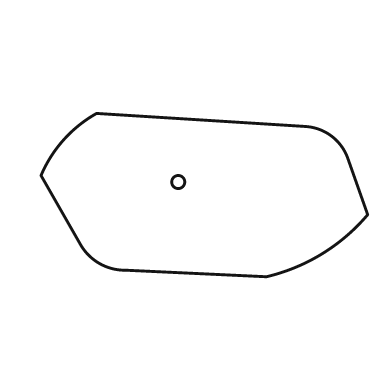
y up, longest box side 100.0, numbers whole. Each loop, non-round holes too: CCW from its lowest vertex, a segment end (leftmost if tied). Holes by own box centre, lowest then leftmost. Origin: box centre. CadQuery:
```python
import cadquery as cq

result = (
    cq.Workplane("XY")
    .moveTo(19.0, -25.0)
    .threePointArc((36.0, -18.0), (50.0, -6.0))
    .lineTo(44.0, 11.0)
    .threePointArc((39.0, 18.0), (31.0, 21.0))
    .lineTo(-33.0, 25.0)
    .threePointArc((-43.0, 17.0), (-50.0, 6.0))
    .lineTo(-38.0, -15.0)
    .threePointArc((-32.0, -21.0), (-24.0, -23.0))
    .close()
    .moveTo(-8.0, 4.0)
    .circle(2.0)
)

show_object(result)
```